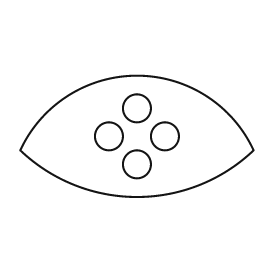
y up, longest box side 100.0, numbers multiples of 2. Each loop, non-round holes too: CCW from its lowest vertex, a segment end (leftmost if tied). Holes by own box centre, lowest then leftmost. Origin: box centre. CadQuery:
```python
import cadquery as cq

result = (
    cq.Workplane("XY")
    .moveTo(-50.0, -6.0)
    .threePointArc((0.0, -26.0), (50.0, -6.0))
    .threePointArc((0.0, 26.0), (-50.0, -6.0))
    .close()
    .moveTo(0.0, -12.0)
    .circle(6.0)
    .moveTo(-12.0, 0.0)
    .circle(6.0)
    .moveTo(12.0, 0.0)
    .circle(6.0)
    .moveTo(0.0, 12.0)
    .circle(6.0)
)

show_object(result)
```